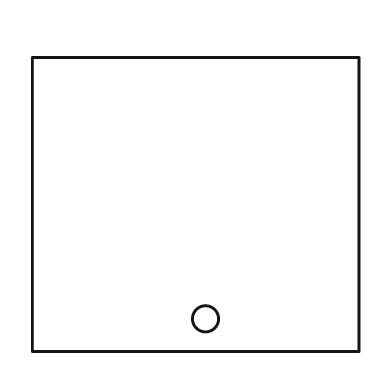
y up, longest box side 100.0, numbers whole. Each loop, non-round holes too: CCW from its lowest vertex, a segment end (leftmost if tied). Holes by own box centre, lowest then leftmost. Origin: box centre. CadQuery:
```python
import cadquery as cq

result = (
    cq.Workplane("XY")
    .moveTo(-50.0, -45.0)
    .lineTo(50.0, -45.0)
    .lineTo(50.0, 45.0)
    .lineTo(-50.0, 45.0)
    .close()
    .moveTo(3.0, -35.0)
    .circle(4.0)
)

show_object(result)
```